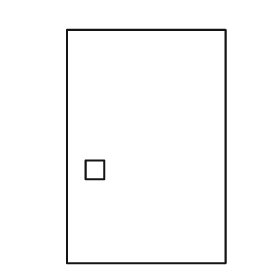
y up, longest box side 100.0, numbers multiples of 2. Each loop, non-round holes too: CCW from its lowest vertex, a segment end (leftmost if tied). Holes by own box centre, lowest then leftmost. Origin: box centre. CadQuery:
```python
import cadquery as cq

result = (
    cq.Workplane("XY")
    .moveTo(-34.0, -50.0)
    .lineTo(34.0, -50.0)
    .lineTo(34.0, 50.0)
    .lineTo(-34.0, 50.0)
    .close()
    .moveTo(-26.0, -14.0)
    .lineTo(-18.0, -14.0)
    .lineTo(-18.0, -6.0)
    .lineTo(-26.0, -6.0)
    .close()
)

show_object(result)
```